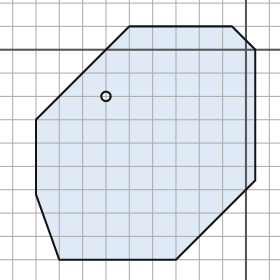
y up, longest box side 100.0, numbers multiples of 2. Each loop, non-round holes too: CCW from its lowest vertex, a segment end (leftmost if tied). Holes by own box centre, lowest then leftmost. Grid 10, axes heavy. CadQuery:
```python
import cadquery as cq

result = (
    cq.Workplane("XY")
    .moveTo(-80.0, -90.0)
    .lineTo(-30.0, -90.0)
    .lineTo(4.0, -56.0)
    .lineTo(4.0, 0.0)
    .lineTo(-6.0, 10.0)
    .lineTo(-50.0, 10.0)
    .lineTo(-90.0, -30.0)
    .lineTo(-90.0, -62.0)
    .close()
    .moveTo(-60.0, -20.0)
    .circle(2.0)
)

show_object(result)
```